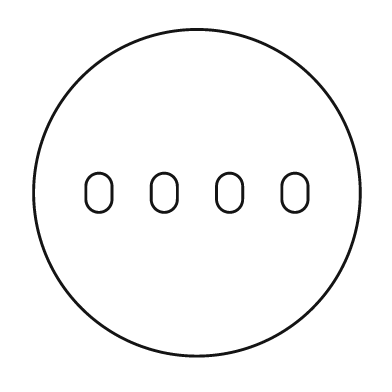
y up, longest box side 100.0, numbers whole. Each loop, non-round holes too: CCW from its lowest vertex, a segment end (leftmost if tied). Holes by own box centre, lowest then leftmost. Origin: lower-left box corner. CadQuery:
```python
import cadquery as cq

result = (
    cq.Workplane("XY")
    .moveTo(50.0, 50.0)
    .circle(50.0)
    .moveTo(16.0, 48.0)
    .threePointArc((20.0, 44.0), (24.0, 48.0))
    .lineTo(24.0, 52.0)
    .threePointArc((20.0, 56.0), (16.0, 52.0))
    .close()
    .moveTo(36.0, 48.0)
    .threePointArc((40.0, 44.0), (44.0, 48.0))
    .lineTo(44.0, 52.0)
    .threePointArc((40.0, 56.0), (36.0, 52.0))
    .close()
    .moveTo(56.0, 48.0)
    .threePointArc((60.0, 44.0), (64.0, 48.0))
    .lineTo(64.0, 52.0)
    .threePointArc((60.0, 56.0), (56.0, 52.0))
    .close()
    .moveTo(76.0, 48.0)
    .threePointArc((80.0, 44.0), (84.0, 48.0))
    .lineTo(84.0, 52.0)
    .threePointArc((80.0, 56.0), (76.0, 52.0))
    .close()
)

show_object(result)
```